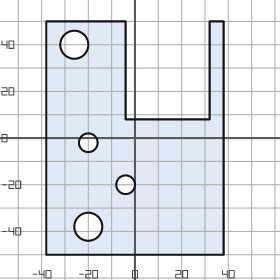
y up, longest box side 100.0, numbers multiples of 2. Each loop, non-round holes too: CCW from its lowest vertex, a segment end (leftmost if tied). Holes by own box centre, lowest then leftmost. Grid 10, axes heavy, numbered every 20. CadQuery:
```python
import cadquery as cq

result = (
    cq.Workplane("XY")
    .moveTo(-38.0, -50.0)
    .lineTo(38.0, -50.0)
    .lineTo(38.0, 50.0)
    .lineTo(32.0, 50.0)
    .lineTo(32.0, 8.0)
    .lineTo(-4.0, 8.0)
    .lineTo(-4.0, 50.0)
    .lineTo(-38.0, 50.0)
    .close()
    .moveTo(-20.0, -38.0)
    .circle(6.0)
    .moveTo(-4.0, -20.0)
    .circle(4.0)
    .moveTo(-20.0, -2.0)
    .circle(4.0)
    .moveTo(-26.0, 40.0)
    .circle(6.0)
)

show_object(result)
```